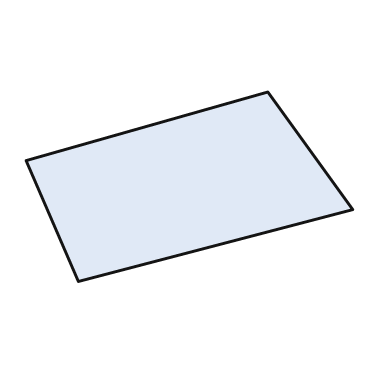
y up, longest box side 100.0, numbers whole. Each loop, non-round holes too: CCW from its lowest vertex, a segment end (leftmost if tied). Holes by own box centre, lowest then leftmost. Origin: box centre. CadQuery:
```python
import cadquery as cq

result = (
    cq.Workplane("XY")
    .moveTo(-34.0, -29.0)
    .lineTo(50.0, -7.0)
    .lineTo(24.0, 29.0)
    .lineTo(-50.0, 8.0)
    .close()
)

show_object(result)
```